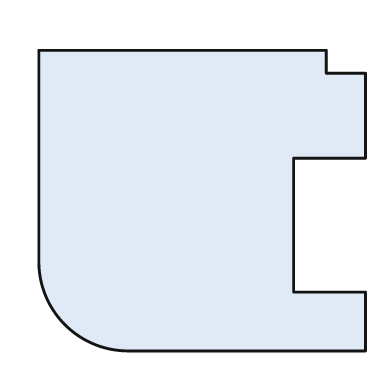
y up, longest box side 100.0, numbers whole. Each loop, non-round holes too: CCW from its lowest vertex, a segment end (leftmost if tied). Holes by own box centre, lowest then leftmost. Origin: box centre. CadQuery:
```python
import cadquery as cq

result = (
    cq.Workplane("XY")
    .moveTo(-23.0, -46.0)
    .lineTo(50.0, -46.0)
    .lineTo(50.0, -28.0)
    .lineTo(28.0, -28.0)
    .lineTo(28.0, 13.0)
    .lineTo(50.0, 13.0)
    .lineTo(50.0, 39.0)
    .lineTo(38.0, 39.0)
    .lineTo(38.0, 46.0)
    .lineTo(-50.0, 46.0)
    .lineTo(-50.0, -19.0)
    .threePointArc((-42.0, -38.0), (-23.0, -46.0))
    .close()
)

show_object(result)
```